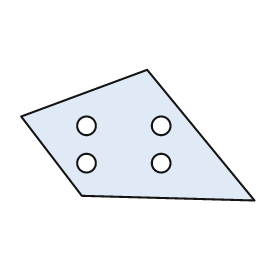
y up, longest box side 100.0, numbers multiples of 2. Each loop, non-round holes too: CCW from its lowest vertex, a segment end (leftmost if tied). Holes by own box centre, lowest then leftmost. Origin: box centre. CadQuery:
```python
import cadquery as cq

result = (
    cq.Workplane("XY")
    .moveTo(50.0, -28.0)
    .lineTo(4.0, 28.0)
    .lineTo(-50.0, 8.0)
    .lineTo(-24.0, -26.0)
    .close()
    .moveTo(-22.0, -12.0)
    .circle(4.0)
    .moveTo(10.0, -12.0)
    .circle(4.0)
    .moveTo(-22.0, 4.0)
    .circle(4.0)
    .moveTo(10.0, 4.0)
    .circle(4.0)
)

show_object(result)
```